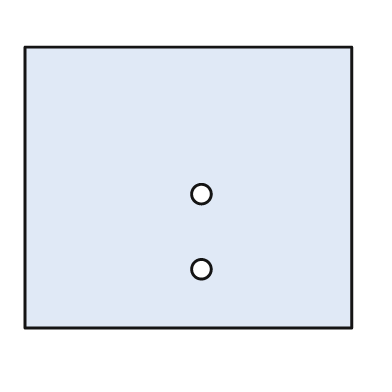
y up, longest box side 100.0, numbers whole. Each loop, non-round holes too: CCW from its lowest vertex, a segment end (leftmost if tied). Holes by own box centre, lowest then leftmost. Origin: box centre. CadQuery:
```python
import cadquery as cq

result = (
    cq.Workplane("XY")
    .moveTo(-50.0, -43.0)
    .lineTo(50.0, -43.0)
    .lineTo(50.0, 43.0)
    .lineTo(-50.0, 43.0)
    .close()
    .moveTo(4.0, -25.0)
    .circle(3.0)
    .moveTo(4.0, -2.0)
    .circle(3.0)
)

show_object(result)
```